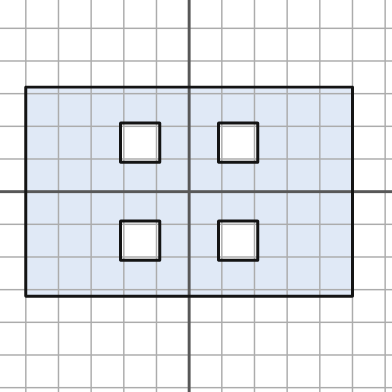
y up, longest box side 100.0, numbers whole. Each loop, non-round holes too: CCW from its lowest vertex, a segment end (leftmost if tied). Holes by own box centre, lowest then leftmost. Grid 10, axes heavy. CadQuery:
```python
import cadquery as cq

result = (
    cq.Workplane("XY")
    .moveTo(-50.0, -32.0)
    .lineTo(50.0, -32.0)
    .lineTo(50.0, 32.0)
    .lineTo(-50.0, 32.0)
    .close()
    .moveTo(-21.0, -21.0)
    .lineTo(-9.0, -21.0)
    .lineTo(-9.0, -9.0)
    .lineTo(-21.0, -9.0)
    .close()
    .moveTo(9.0, -21.0)
    .lineTo(21.0, -21.0)
    .lineTo(21.0, -9.0)
    .lineTo(9.0, -9.0)
    .close()
    .moveTo(-21.0, 9.0)
    .lineTo(-9.0, 9.0)
    .lineTo(-9.0, 21.0)
    .lineTo(-21.0, 21.0)
    .close()
    .moveTo(9.0, 9.0)
    .lineTo(21.0, 9.0)
    .lineTo(21.0, 21.0)
    .lineTo(9.0, 21.0)
    .close()
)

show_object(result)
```